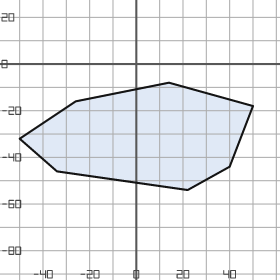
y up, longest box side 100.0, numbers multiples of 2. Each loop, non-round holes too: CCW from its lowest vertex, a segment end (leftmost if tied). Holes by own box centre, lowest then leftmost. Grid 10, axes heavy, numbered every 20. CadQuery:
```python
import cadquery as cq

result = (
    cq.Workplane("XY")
    .moveTo(22.0, -54.0)
    .lineTo(40.0, -44.0)
    .lineTo(50.0, -18.0)
    .lineTo(14.0, -8.0)
    .lineTo(-26.0, -16.0)
    .lineTo(-50.0, -32.0)
    .lineTo(-34.0, -46.0)
    .close()
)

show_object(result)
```